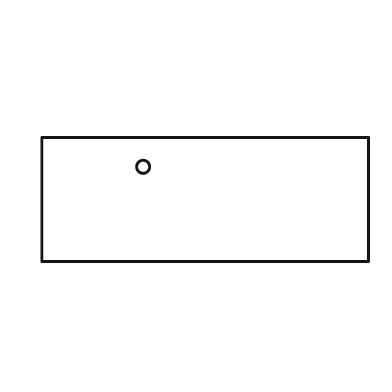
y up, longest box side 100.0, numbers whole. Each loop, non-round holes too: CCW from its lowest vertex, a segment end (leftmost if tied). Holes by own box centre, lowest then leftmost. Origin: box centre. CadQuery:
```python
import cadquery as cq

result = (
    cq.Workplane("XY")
    .moveTo(-50.0, -19.0)
    .lineTo(50.0, -19.0)
    .lineTo(50.0, 19.0)
    .lineTo(-50.0, 19.0)
    .close()
    .moveTo(-19.0, 10.0)
    .circle(2.0)
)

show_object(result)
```